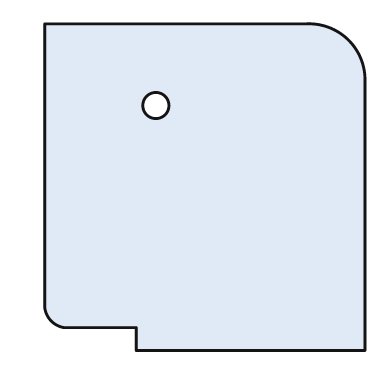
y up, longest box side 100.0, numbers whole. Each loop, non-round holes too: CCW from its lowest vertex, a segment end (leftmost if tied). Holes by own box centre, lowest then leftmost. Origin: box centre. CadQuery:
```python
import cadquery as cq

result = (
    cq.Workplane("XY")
    .moveTo(-21.0, -50.0)
    .lineTo(49.0, -50.0)
    .lineTo(49.0, 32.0)
    .threePointArc((44.0, 45.0), (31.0, 50.0))
    .lineTo(-49.0, 50.0)
    .lineTo(-49.0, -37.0)
    .threePointArc((-47.0, -41.0), (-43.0, -43.0))
    .lineTo(-21.0, -43.0)
    .close()
    .moveTo(-15.0, 25.0)
    .circle(4.0)
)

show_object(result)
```